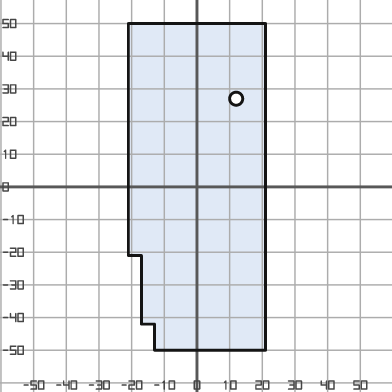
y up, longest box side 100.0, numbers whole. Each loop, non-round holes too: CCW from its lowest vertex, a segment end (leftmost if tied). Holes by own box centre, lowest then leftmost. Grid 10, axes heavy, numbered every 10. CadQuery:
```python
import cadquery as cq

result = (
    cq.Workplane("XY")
    .moveTo(-13.0, -50.0)
    .lineTo(21.0, -50.0)
    .lineTo(21.0, 50.0)
    .lineTo(-21.0, 50.0)
    .lineTo(-21.0, -21.0)
    .lineTo(-17.0, -21.0)
    .lineTo(-17.0, -42.0)
    .lineTo(-13.0, -42.0)
    .close()
    .moveTo(12.0, 27.0)
    .circle(2.0)
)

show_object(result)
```